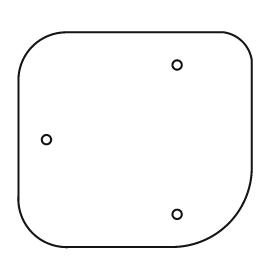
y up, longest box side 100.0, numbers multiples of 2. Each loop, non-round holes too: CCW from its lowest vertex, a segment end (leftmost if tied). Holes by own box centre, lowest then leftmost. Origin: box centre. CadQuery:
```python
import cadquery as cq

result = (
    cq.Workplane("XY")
    .moveTo(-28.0, -46.0)
    .lineTo(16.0, -46.0)
    .threePointArc((40.0, -36.0), (50.0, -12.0))
    .lineTo(50.0, 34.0)
    .threePointArc((46.0, 42.0), (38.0, 46.0))
    .lineTo(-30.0, 46.0)
    .threePointArc((-44.0, 40.0), (-50.0, 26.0))
    .lineTo(-50.0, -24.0)
    .threePointArc((-44.0, -40.0), (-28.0, -46.0))
    .close()
    .moveTo(18.0, -32.0)
    .circle(2.0)
    .moveTo(-38.0, 0.0)
    .circle(2.0)
    .moveTo(18.0, 32.0)
    .circle(2.0)
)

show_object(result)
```